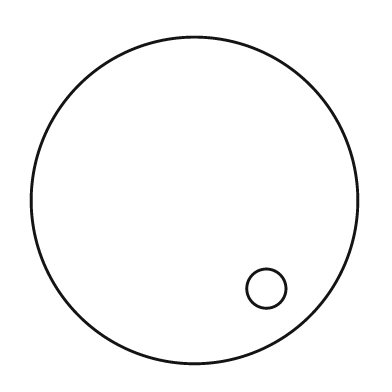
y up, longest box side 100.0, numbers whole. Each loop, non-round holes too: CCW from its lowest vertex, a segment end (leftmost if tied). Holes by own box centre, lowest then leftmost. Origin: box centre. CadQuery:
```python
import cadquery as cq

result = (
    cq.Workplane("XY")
    .moveTo(0.0, 0.0)
    .circle(50.0)
    .moveTo(22.0, -27.0)
    .circle(6.0)
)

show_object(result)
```